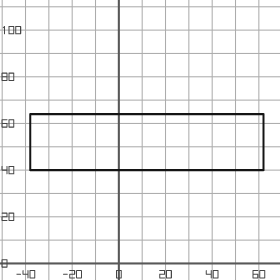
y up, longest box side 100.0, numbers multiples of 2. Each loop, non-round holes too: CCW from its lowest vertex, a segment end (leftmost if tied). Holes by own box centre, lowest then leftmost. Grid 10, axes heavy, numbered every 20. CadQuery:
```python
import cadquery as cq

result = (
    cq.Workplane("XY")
    .moveTo(-38.0, 40.0)
    .lineTo(62.0, 40.0)
    .lineTo(62.0, 64.0)
    .lineTo(-38.0, 64.0)
    .close()
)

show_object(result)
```